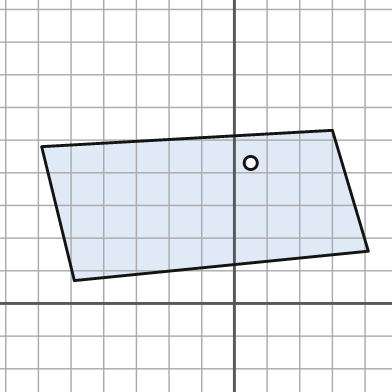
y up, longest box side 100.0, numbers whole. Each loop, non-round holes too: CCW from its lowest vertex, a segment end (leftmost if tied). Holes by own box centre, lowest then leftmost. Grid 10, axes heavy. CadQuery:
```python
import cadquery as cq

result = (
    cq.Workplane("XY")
    .moveTo(-49.0, 7.0)
    .lineTo(41.0, 16.0)
    .lineTo(30.0, 53.0)
    .lineTo(-59.0, 48.0)
    .close()
    .moveTo(5.0, 43.0)
    .circle(2.0)
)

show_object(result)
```